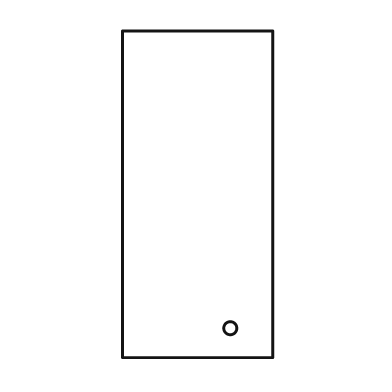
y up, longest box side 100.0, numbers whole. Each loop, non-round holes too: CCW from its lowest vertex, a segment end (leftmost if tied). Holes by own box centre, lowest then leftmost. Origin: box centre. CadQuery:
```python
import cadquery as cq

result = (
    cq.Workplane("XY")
    .moveTo(-23.0, -50.0)
    .lineTo(23.0, -50.0)
    .lineTo(23.0, 50.0)
    .lineTo(-23.0, 50.0)
    .close()
    .moveTo(10.0, -41.0)
    .circle(2.0)
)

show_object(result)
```